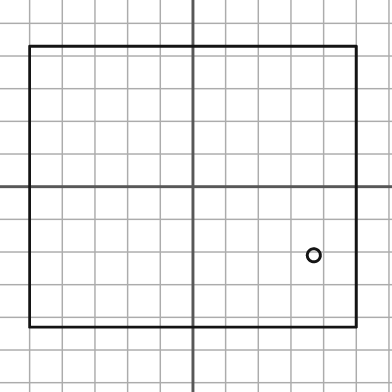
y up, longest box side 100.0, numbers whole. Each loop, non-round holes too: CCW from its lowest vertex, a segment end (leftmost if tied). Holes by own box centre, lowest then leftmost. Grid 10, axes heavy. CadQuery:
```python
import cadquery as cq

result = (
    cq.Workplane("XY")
    .moveTo(-50.0, -43.0)
    .lineTo(50.0, -43.0)
    .lineTo(50.0, 43.0)
    .lineTo(-50.0, 43.0)
    .close()
    .moveTo(37.0, -21.0)
    .circle(2.0)
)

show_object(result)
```